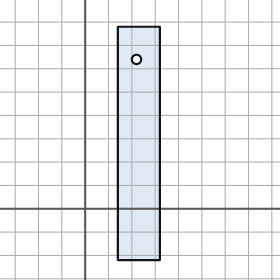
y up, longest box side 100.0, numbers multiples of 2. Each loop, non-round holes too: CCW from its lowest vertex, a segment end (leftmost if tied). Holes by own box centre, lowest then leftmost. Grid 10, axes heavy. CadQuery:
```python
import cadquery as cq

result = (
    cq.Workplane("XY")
    .moveTo(14.0, -22.0)
    .lineTo(32.0, -22.0)
    .lineTo(32.0, 78.0)
    .lineTo(14.0, 78.0)
    .close()
    .moveTo(22.0, 64.0)
    .circle(2.0)
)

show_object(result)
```